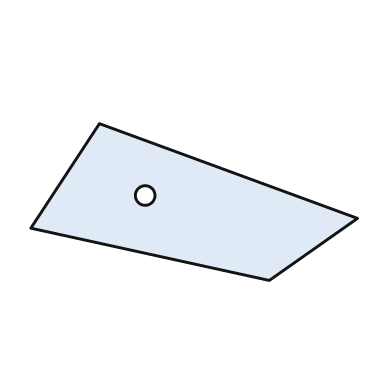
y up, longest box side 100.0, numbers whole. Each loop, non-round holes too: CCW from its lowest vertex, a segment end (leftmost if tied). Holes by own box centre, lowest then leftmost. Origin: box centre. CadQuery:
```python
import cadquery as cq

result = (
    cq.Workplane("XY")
    .moveTo(23.0, -24.0)
    .lineTo(50.0, -5.0)
    .lineTo(-29.0, 24.0)
    .lineTo(-50.0, -8.0)
    .close()
    .moveTo(-15.0, 2.0)
    .circle(3.0)
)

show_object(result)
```